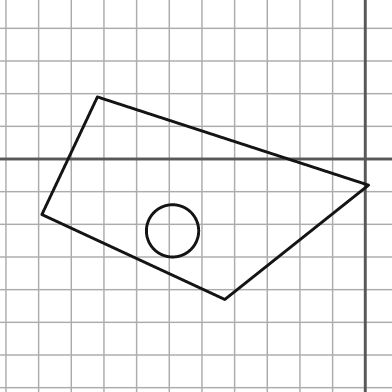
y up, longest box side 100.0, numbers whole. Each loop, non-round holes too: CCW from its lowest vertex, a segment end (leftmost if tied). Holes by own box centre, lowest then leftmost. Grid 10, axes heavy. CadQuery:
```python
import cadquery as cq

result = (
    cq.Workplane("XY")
    .moveTo(-43.0, -43.0)
    .lineTo(1.0, -8.0)
    .lineTo(-82.0, 19.0)
    .lineTo(-99.0, -17.0)
    .close()
    .moveTo(-59.0, -22.0)
    .circle(8.0)
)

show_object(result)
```